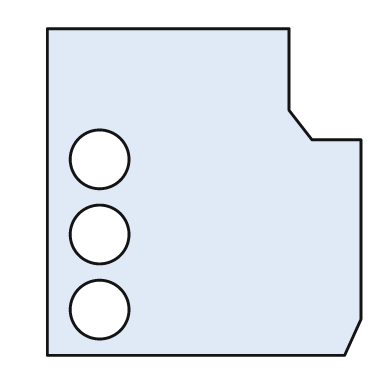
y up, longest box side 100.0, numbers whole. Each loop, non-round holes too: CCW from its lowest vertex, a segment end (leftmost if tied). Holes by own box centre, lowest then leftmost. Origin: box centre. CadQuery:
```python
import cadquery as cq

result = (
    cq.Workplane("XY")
    .moveTo(-48.0, -50.0)
    .lineTo(43.0, -50.0)
    .lineTo(48.0, -39.0)
    .lineTo(48.0, 16.0)
    .lineTo(33.0, 16.0)
    .lineTo(26.0, 25.0)
    .lineTo(26.0, 50.0)
    .lineTo(-48.0, 50.0)
    .close()
    .moveTo(-32.0, -36.0)
    .circle(9.0)
    .moveTo(-32.0, -13.0)
    .circle(9.0)
    .moveTo(-32.0, 10.0)
    .circle(9.0)
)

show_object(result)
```